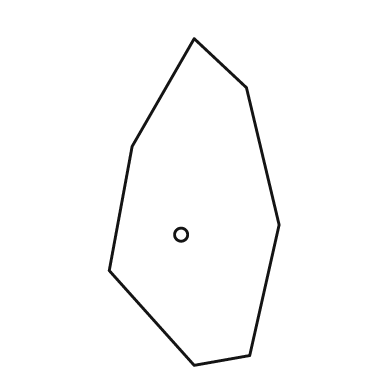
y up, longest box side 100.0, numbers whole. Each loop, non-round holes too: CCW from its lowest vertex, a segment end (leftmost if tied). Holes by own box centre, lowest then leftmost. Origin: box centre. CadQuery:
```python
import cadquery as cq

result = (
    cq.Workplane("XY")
    .moveTo(0.0, -50.0)
    .lineTo(17.0, -47.0)
    .lineTo(26.0, -7.0)
    .lineTo(16.0, 35.0)
    .lineTo(0.0, 50.0)
    .lineTo(-19.0, 17.0)
    .lineTo(-26.0, -21.0)
    .close()
    .moveTo(-4.0, -10.0)
    .circle(2.0)
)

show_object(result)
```